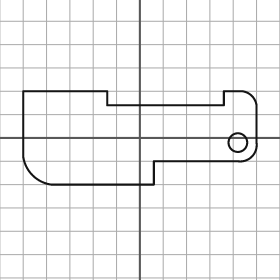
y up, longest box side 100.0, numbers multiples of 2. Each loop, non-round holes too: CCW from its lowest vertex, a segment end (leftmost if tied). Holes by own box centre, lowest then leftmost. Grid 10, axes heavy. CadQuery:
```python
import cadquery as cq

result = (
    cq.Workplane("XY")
    .moveTo(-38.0, -20.0)
    .lineTo(6.0, -20.0)
    .lineTo(6.0, -10.0)
    .lineTo(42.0, -10.0)
    .threePointArc((48.0, -8.0), (50.0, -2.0))
    .lineTo(50.0, 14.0)
    .threePointArc((48.0, 18.0), (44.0, 20.0))
    .lineTo(36.0, 20.0)
    .lineTo(36.0, 14.0)
    .lineTo(-14.0, 14.0)
    .lineTo(-14.0, 20.0)
    .lineTo(-50.0, 20.0)
    .lineTo(-50.0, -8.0)
    .threePointArc((-46.0, -16.0), (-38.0, -20.0))
    .close()
    .moveTo(42.0, -2.0)
    .circle(4.0)
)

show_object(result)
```